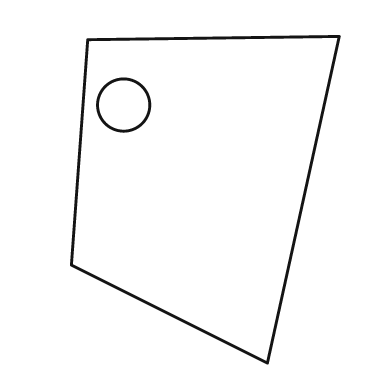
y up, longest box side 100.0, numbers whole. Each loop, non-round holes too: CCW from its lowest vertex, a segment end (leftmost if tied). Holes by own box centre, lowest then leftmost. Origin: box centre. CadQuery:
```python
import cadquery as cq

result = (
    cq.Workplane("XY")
    .moveTo(19.0, -50.0)
    .lineTo(41.0, 50.0)
    .lineTo(-36.0, 49.0)
    .lineTo(-41.0, -20.0)
    .close()
    .moveTo(-25.0, 29.0)
    .circle(8.0)
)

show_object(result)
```